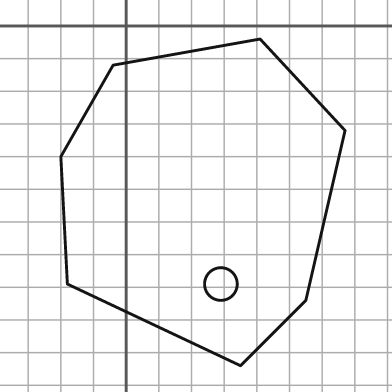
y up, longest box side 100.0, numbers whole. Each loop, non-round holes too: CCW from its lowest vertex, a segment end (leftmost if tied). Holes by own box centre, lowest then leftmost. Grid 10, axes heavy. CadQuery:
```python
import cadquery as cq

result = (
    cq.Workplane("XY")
    .moveTo(35.0, -104.0)
    .lineTo(55.0, -84.0)
    .lineTo(67.0, -32.0)
    .lineTo(41.0, -4.0)
    .lineTo(-4.0, -12.0)
    .lineTo(-20.0, -40.0)
    .lineTo(-18.0, -79.0)
    .close()
    .moveTo(29.0, -79.0)
    .circle(5.0)
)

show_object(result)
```